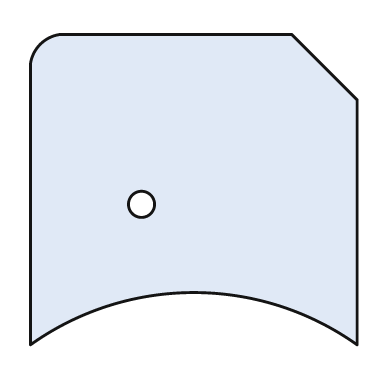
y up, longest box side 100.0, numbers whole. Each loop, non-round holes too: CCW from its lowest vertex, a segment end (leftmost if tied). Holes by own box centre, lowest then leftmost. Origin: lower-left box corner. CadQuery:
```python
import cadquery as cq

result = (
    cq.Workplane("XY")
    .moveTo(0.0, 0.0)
    .threePointArc((50.0, 16.0), (100.0, 0.0))
    .lineTo(100.0, 75.0)
    .lineTo(80.0, 95.0)
    .lineTo(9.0, 95.0)
    .threePointArc((3.0, 92.0), (0.0, 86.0))
    .close()
    .moveTo(34.0, 43.0)
    .circle(4.0)
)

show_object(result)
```